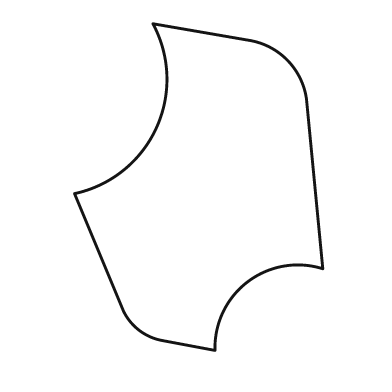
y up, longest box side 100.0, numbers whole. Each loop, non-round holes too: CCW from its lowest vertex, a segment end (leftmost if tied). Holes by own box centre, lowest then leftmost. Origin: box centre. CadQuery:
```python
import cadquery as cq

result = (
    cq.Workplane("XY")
    .moveTo(5.0, -50.0)
    .threePointArc((15.0, -29.0), (38.0, -25.0))
    .lineTo(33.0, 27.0)
    .threePointArc((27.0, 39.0), (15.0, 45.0))
    .lineTo(-14.0, 50.0)
    .threePointArc((-13.0, 18.0), (-38.0, -2.0))
    .lineTo(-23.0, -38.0)
    .threePointArc((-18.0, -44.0), (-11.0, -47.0))
    .close()
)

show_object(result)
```